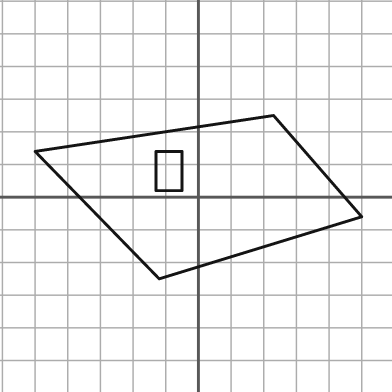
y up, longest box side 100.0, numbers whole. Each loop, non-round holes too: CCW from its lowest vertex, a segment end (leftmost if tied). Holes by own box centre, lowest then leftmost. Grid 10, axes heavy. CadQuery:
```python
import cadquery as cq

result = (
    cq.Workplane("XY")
    .moveTo(-12.0, -25.0)
    .lineTo(50.0, -6.0)
    .lineTo(23.0, 25.0)
    .lineTo(-50.0, 14.0)
    .close()
    .moveTo(-13.0, 2.0)
    .lineTo(-5.0, 2.0)
    .lineTo(-5.0, 14.0)
    .lineTo(-13.0, 14.0)
    .close()
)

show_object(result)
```